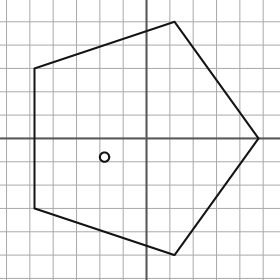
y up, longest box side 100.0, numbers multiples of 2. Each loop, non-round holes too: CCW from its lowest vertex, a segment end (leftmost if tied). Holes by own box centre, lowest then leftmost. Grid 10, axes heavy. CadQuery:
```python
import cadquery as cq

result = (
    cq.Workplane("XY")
    .moveTo(12.0, -50.0)
    .lineTo(48.0, 0.0)
    .lineTo(12.0, 50.0)
    .lineTo(-48.0, 30.0)
    .lineTo(-48.0, -30.0)
    .close()
    .moveTo(-18.0, -8.0)
    .circle(2.0)
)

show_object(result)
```